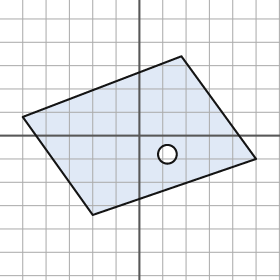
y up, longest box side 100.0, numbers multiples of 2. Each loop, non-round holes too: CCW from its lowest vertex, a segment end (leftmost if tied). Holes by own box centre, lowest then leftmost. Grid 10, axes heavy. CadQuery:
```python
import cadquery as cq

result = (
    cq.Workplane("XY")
    .moveTo(-20.0, -34.0)
    .lineTo(50.0, -10.0)
    .lineTo(18.0, 34.0)
    .lineTo(-50.0, 8.0)
    .close()
    .moveTo(12.0, -8.0)
    .circle(4.0)
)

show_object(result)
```